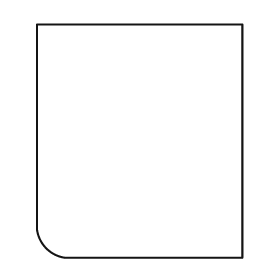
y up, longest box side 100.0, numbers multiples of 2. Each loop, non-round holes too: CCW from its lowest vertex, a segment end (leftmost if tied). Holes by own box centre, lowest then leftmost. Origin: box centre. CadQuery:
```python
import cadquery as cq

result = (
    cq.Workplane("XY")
    .moveTo(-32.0, -50.0)
    .lineTo(44.0, -50.0)
    .lineTo(44.0, 50.0)
    .lineTo(-44.0, 50.0)
    .lineTo(-44.0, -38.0)
    .threePointArc((-40.0, -46.0), (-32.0, -50.0))
    .close()
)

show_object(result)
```